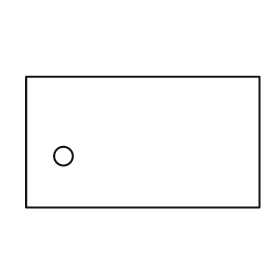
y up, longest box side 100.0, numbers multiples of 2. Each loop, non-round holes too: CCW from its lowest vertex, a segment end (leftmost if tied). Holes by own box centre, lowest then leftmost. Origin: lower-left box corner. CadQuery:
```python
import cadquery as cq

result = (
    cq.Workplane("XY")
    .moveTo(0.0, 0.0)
    .lineTo(100.0, 0.0)
    .lineTo(100.0, 56.0)
    .lineTo(0.0, 56.0)
    .close()
    .moveTo(16.0, 22.0)
    .circle(4.0)
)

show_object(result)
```